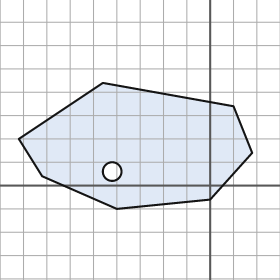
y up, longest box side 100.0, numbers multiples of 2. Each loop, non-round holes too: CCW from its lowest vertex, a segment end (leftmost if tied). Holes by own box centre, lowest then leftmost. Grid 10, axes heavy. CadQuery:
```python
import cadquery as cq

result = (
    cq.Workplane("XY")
    .moveTo(-40.0, -10.0)
    .lineTo(0.0, -6.0)
    .lineTo(18.0, 14.0)
    .lineTo(10.0, 34.0)
    .lineTo(-46.0, 44.0)
    .lineTo(-82.0, 20.0)
    .lineTo(-72.0, 4.0)
    .close()
    .moveTo(-42.0, 6.0)
    .circle(4.0)
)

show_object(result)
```